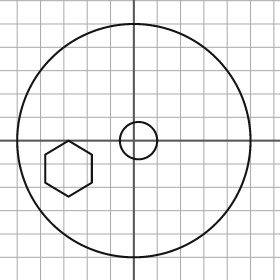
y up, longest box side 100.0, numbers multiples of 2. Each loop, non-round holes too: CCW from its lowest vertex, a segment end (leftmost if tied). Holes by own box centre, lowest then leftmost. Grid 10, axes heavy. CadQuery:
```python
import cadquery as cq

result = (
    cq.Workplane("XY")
    .moveTo(0.0, 0.0)
    .circle(50.0)
    .moveTo(-28.0, -24.0)
    .lineTo(-18.0, -18.0)
    .lineTo(-18.0, -6.0)
    .lineTo(-28.0, 0.0)
    .lineTo(-38.0, -6.0)
    .lineTo(-38.0, -18.0)
    .close()
    .moveTo(2.0, 0.0)
    .circle(8.0)
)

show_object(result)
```